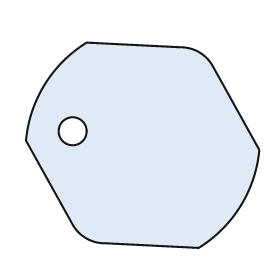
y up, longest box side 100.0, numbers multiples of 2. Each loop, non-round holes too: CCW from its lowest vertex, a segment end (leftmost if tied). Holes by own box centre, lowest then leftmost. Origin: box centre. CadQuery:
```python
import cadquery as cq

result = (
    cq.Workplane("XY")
    .moveTo(24.0, -44.0)
    .threePointArc((42.0, -26.0), (50.0, -2.0))
    .lineTo(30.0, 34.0)
    .threePointArc((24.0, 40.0), (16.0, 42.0))
    .lineTo(-24.0, 44.0)
    .threePointArc((-42.0, 26.0), (-50.0, 2.0))
    .lineTo(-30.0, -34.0)
    .threePointArc((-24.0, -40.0), (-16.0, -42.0))
    .close()
    .moveTo(-30.0, 6.0)
    .circle(6.0)
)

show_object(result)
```